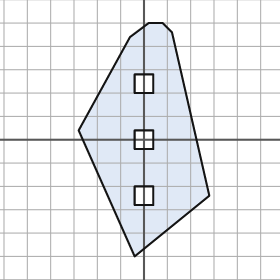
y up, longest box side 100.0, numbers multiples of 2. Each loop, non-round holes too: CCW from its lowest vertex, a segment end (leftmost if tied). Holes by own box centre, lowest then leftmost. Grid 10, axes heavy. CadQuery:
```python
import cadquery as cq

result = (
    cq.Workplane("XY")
    .moveTo(-4.0, -50.0)
    .lineTo(28.0, -24.0)
    .lineTo(12.0, 46.0)
    .lineTo(8.0, 50.0)
    .lineTo(2.0, 50.0)
    .lineTo(-6.0, 44.0)
    .lineTo(-28.0, 4.0)
    .close()
    .moveTo(-4.0, -28.0)
    .lineTo(4.0, -28.0)
    .lineTo(4.0, -20.0)
    .lineTo(-4.0, -20.0)
    .close()
    .moveTo(-4.0, -4.0)
    .lineTo(4.0, -4.0)
    .lineTo(4.0, 4.0)
    .lineTo(-4.0, 4.0)
    .close()
    .moveTo(-4.0, 20.0)
    .lineTo(4.0, 20.0)
    .lineTo(4.0, 28.0)
    .lineTo(-4.0, 28.0)
    .close()
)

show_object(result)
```